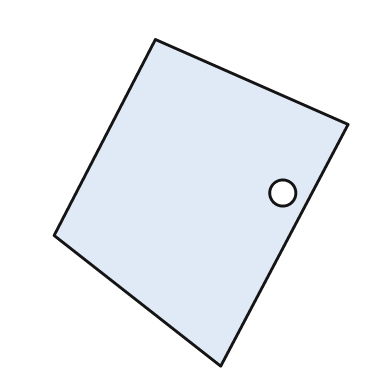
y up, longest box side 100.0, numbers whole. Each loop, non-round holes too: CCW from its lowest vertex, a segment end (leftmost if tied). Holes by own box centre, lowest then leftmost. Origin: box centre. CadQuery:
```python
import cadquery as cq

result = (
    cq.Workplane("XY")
    .moveTo(6.0, -50.0)
    .lineTo(45.0, 24.0)
    .lineTo(-14.0, 50.0)
    .lineTo(-45.0, -10.0)
    .close()
    .moveTo(25.0, 3.0)
    .circle(4.0)
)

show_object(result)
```